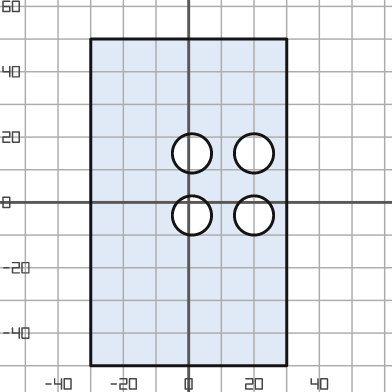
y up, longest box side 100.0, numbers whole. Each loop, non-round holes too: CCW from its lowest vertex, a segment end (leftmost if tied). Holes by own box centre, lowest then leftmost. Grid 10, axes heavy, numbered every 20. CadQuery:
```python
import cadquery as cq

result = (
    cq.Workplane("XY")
    .moveTo(-30.0, -50.0)
    .lineTo(30.0, -50.0)
    .lineTo(30.0, 50.0)
    .lineTo(-30.0, 50.0)
    .close()
    .moveTo(1.0, -4.0)
    .circle(6.0)
    .moveTo(20.0, -4.0)
    .circle(6.0)
    .moveTo(1.0, 15.0)
    .circle(6.0)
    .moveTo(20.0, 15.0)
    .circle(6.0)
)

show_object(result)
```